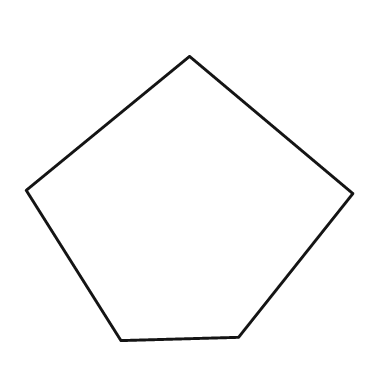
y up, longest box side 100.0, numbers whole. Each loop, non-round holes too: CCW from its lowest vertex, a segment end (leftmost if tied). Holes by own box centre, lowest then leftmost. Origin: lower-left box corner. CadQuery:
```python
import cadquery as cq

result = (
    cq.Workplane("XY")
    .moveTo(29.0, 0.0)
    .lineTo(65.0, 1.0)
    .lineTo(100.0, 45.0)
    .lineTo(50.0, 87.0)
    .lineTo(0.0, 46.0)
    .close()
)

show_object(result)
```